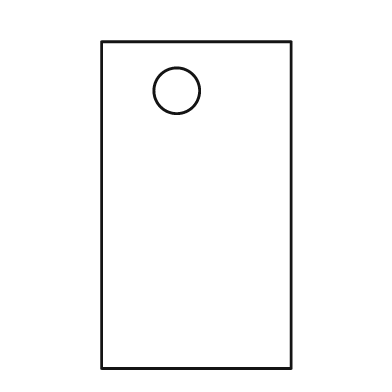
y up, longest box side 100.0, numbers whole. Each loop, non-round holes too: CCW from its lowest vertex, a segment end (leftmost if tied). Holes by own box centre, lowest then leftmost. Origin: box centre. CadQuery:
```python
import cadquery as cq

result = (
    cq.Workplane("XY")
    .moveTo(-29.0, -50.0)
    .lineTo(29.0, -50.0)
    .lineTo(29.0, 50.0)
    .lineTo(-29.0, 50.0)
    .close()
    .moveTo(-6.0, 35.0)
    .circle(7.0)
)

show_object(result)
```